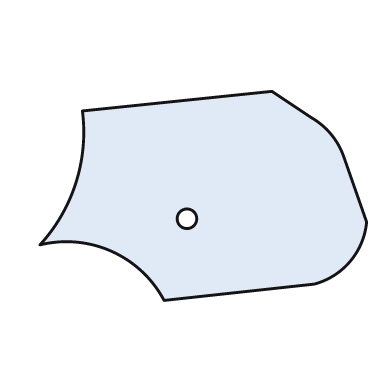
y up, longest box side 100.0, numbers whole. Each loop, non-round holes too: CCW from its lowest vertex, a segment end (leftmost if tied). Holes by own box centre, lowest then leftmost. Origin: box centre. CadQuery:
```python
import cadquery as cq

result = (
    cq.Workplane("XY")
    .moveTo(-12.0, -32.0)
    .lineTo(34.0, -27.0)
    .threePointArc((45.0, -20.0), (50.0, -8.0))
    .lineTo(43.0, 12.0)
    .threePointArc((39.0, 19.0), (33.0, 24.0))
    .lineTo(21.0, 32.0)
    .lineTo(-37.0, 26.0)
    .threePointArc((-39.0, 4.0), (-50.0, -15.0))
    .threePointArc((-28.0, -17.0), (-12.0, -32.0))
    .close()
    .moveTo(-5.0, -7.0)
    .circle(3.0)
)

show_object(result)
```